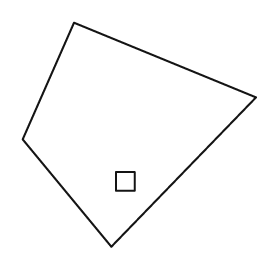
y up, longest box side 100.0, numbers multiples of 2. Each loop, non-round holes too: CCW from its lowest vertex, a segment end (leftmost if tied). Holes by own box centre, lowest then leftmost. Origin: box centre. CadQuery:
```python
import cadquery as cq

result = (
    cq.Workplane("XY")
    .moveTo(-12.0, -48.0)
    .lineTo(50.0, 16.0)
    .lineTo(-28.0, 48.0)
    .lineTo(-50.0, -2.0)
    .close()
    .moveTo(-10.0, -24.0)
    .lineTo(-2.0, -24.0)
    .lineTo(-2.0, -16.0)
    .lineTo(-10.0, -16.0)
    .close()
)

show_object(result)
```